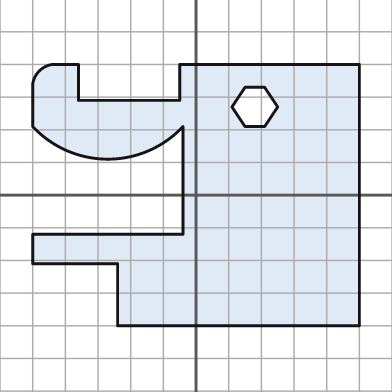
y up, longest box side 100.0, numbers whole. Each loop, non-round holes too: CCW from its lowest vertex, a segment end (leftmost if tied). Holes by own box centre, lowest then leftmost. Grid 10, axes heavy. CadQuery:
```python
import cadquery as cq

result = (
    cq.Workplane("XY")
    .moveTo(-24.0, -40.0)
    .lineTo(50.0, -40.0)
    .lineTo(50.0, 40.0)
    .lineTo(-5.0, 40.0)
    .lineTo(-5.0, 29.0)
    .lineTo(-36.0, 29.0)
    .lineTo(-36.0, 40.0)
    .lineTo(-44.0, 40.0)
    .threePointArc((-48.0, 38.0), (-50.0, 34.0))
    .lineTo(-50.0, 21.0)
    .threePointArc((-27.0, 11.0), (-4.0, 21.0))
    .lineTo(-4.0, -12.0)
    .lineTo(-50.0, -12.0)
    .lineTo(-50.0, -21.0)
    .lineTo(-24.0, -21.0)
    .close()
    .moveTo(15.0, 21.0)
    .lineTo(21.0, 21.0)
    .lineTo(25.0, 27.0)
    .lineTo(21.0, 33.0)
    .lineTo(15.0, 33.0)
    .lineTo(11.0, 27.0)
    .close()
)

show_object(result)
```